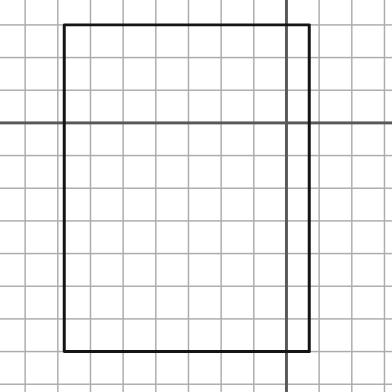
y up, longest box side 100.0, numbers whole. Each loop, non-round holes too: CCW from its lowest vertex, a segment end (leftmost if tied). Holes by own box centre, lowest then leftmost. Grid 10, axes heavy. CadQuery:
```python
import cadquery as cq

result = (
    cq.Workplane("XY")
    .moveTo(-68.0, -70.0)
    .lineTo(7.0, -70.0)
    .lineTo(7.0, 30.0)
    .lineTo(-68.0, 30.0)
    .close()
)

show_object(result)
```